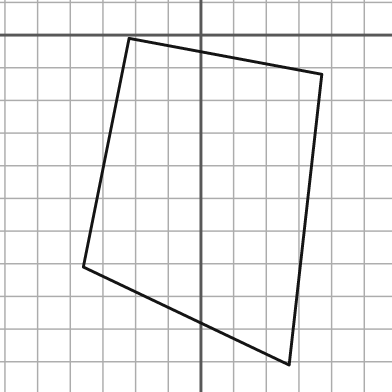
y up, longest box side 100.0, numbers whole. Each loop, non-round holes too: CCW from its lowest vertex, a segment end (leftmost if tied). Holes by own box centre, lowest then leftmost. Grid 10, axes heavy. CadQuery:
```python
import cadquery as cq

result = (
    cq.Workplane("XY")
    .moveTo(27.0, -101.0)
    .lineTo(37.0, -12.0)
    .lineTo(-22.0, -1.0)
    .lineTo(-36.0, -71.0)
    .close()
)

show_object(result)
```